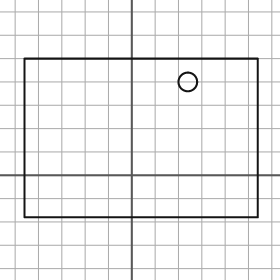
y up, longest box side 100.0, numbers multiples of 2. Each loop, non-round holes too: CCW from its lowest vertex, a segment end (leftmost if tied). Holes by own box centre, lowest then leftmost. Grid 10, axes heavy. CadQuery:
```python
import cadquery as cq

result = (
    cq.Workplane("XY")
    .moveTo(-46.0, -18.0)
    .lineTo(54.0, -18.0)
    .lineTo(54.0, 50.0)
    .lineTo(-46.0, 50.0)
    .close()
    .moveTo(24.0, 40.0)
    .circle(4.0)
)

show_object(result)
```